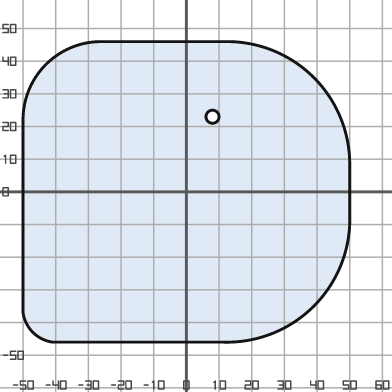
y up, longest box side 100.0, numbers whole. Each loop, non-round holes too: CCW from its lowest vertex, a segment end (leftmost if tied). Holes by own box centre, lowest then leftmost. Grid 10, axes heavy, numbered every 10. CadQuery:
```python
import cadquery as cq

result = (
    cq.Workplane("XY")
    .moveTo(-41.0, -46.0)
    .lineTo(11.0, -46.0)
    .threePointArc((39.0, -35.0), (50.0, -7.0))
    .lineTo(50.0, 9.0)
    .threePointArc((39.0, 35.0), (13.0, 46.0))
    .lineTo(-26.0, 46.0)
    .threePointArc((-43.0, 39.0), (-50.0, 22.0))
    .lineTo(-50.0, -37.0)
    .threePointArc((-47.0, -43.0), (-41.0, -46.0))
    .close()
    .moveTo(8.0, 23.0)
    .circle(2.0)
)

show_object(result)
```